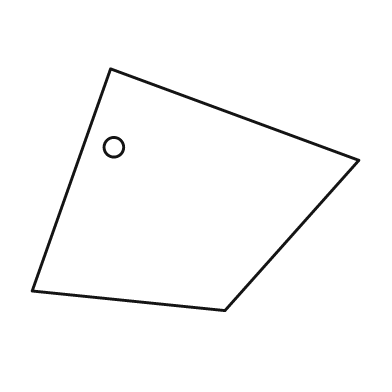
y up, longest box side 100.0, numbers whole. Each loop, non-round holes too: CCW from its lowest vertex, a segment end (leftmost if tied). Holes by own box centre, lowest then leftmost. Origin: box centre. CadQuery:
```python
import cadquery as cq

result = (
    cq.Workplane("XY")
    .moveTo(9.0, -37.0)
    .lineTo(50.0, 9.0)
    .lineTo(-26.0, 37.0)
    .lineTo(-50.0, -31.0)
    .close()
    .moveTo(-25.0, 13.0)
    .circle(3.0)
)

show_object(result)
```